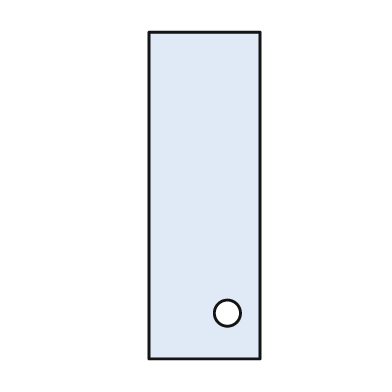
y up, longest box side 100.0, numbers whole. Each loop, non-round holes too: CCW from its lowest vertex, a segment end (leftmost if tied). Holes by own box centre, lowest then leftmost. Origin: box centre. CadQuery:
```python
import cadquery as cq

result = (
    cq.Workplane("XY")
    .moveTo(-17.0, -50.0)
    .lineTo(17.0, -50.0)
    .lineTo(17.0, 50.0)
    .lineTo(-17.0, 50.0)
    .close()
    .moveTo(7.0, -36.0)
    .circle(4.0)
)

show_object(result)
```